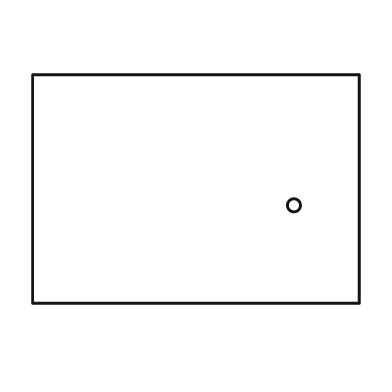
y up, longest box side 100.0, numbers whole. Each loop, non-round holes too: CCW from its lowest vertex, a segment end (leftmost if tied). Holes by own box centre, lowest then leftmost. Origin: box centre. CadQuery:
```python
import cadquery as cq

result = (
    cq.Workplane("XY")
    .moveTo(-50.0, -35.0)
    .lineTo(50.0, -35.0)
    .lineTo(50.0, 35.0)
    .lineTo(-50.0, 35.0)
    .close()
    .moveTo(30.0, -5.0)
    .circle(2.0)
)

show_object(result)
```